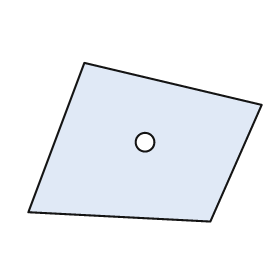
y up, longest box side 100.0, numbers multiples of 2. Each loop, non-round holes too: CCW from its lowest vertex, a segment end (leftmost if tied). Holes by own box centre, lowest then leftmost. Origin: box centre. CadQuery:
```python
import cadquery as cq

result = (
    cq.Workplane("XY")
    .moveTo(28.0, -34.0)
    .lineTo(50.0, 16.0)
    .lineTo(-26.0, 34.0)
    .lineTo(-50.0, -30.0)
    .close()
    .moveTo(0.0, 0.0)
    .circle(4.0)
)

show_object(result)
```